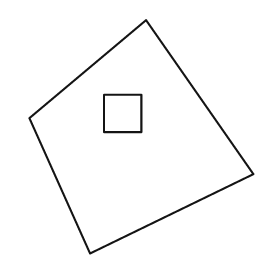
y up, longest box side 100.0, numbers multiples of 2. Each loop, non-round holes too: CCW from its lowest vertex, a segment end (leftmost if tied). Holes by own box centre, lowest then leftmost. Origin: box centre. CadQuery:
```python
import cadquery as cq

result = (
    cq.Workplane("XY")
    .moveTo(-22.0, -50.0)
    .lineTo(48.0, -16.0)
    .lineTo(2.0, 50.0)
    .lineTo(-48.0, 8.0)
    .close()
    .moveTo(-16.0, 2.0)
    .lineTo(0.0, 2.0)
    .lineTo(0.0, 18.0)
    .lineTo(-16.0, 18.0)
    .close()
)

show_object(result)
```